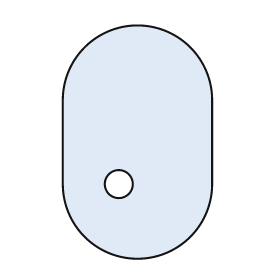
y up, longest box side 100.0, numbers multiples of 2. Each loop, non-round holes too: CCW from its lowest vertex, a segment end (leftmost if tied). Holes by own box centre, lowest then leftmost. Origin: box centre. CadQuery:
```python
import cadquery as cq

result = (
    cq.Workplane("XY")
    .moveTo(-32.0, -18.0)
    .threePointArc((0.0, -50.0), (32.0, -18.0))
    .lineTo(32.0, 18.0)
    .threePointArc((0.0, 50.0), (-32.0, 18.0))
    .close()
    .moveTo(-8.0, -18.0)
    .circle(6.0)
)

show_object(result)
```